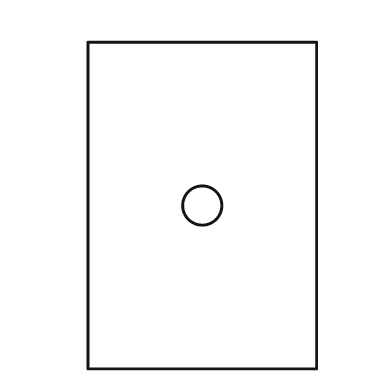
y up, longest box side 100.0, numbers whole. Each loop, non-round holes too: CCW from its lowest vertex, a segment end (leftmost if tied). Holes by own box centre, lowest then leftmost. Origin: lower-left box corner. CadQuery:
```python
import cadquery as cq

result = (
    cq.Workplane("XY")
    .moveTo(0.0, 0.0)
    .lineTo(70.0, 0.0)
    .lineTo(70.0, 100.0)
    .lineTo(0.0, 100.0)
    .close()
    .moveTo(35.0, 50.0)
    .circle(6.0)
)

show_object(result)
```